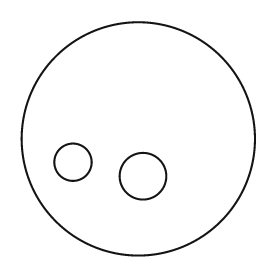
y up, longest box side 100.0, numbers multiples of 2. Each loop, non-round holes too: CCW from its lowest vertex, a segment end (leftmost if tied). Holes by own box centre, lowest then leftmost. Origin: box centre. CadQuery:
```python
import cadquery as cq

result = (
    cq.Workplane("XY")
    .moveTo(0.0, 0.0)
    .circle(50.0)
    .moveTo(2.0, -16.0)
    .circle(10.0)
    .moveTo(-28.0, -10.0)
    .circle(8.0)
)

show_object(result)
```